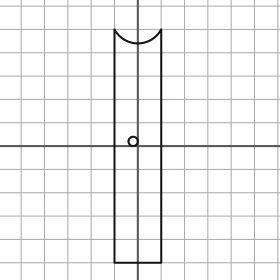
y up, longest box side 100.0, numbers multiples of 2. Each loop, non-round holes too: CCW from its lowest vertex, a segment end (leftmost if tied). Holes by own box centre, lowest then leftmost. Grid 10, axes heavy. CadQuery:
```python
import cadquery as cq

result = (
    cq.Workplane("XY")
    .moveTo(-10.0, -50.0)
    .lineTo(10.0, -50.0)
    .lineTo(10.0, 50.0)
    .threePointArc((0.0, 44.0), (-10.0, 50.0))
    .close()
    .moveTo(-2.0, 2.0)
    .circle(2.0)
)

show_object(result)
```